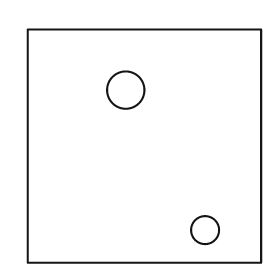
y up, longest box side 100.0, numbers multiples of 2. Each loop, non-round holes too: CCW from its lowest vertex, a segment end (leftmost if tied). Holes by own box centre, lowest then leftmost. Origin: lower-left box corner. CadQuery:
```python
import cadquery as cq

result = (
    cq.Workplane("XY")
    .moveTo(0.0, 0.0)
    .lineTo(100.0, 0.0)
    .lineTo(100.0, 100.0)
    .lineTo(0.0, 100.0)
    .close()
    .moveTo(76.0, 14.0)
    .circle(6.0)
    .moveTo(42.0, 74.0)
    .circle(8.0)
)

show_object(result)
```